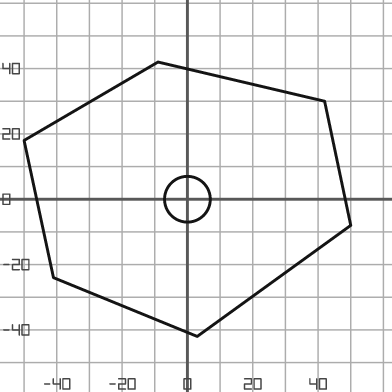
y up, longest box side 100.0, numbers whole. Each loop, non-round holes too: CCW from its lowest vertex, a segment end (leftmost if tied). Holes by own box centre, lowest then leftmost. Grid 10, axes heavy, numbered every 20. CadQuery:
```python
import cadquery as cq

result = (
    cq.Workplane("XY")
    .moveTo(3.0, -42.0)
    .lineTo(50.0, -8.0)
    .lineTo(42.0, 30.0)
    .lineTo(-9.0, 42.0)
    .lineTo(-50.0, 18.0)
    .lineTo(-41.0, -24.0)
    .close()
    .moveTo(0.0, 0.0)
    .circle(7.0)
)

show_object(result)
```